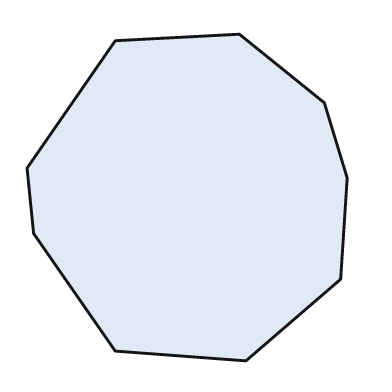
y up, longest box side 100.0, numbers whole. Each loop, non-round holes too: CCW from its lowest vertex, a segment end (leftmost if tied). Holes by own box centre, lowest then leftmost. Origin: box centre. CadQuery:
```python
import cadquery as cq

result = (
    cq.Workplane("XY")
    .moveTo(18.0, -50.0)
    .lineTo(47.0, -25.0)
    .lineTo(49.0, 6.0)
    .lineTo(42.0, 29.0)
    .lineTo(16.0, 50.0)
    .lineTo(-22.0, 48.0)
    .lineTo(-49.0, 9.0)
    .lineTo(-47.0, -11.0)
    .lineTo(-22.0, -47.0)
    .close()
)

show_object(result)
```